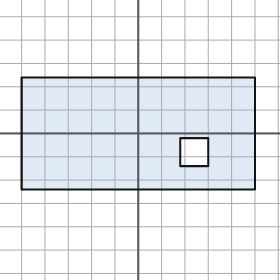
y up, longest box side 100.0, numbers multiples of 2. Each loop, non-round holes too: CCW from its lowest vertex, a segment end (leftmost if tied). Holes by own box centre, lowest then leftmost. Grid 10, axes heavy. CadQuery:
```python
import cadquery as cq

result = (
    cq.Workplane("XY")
    .moveTo(-50.0, -24.0)
    .lineTo(50.0, -24.0)
    .lineTo(50.0, 24.0)
    .lineTo(-50.0, 24.0)
    .close()
    .moveTo(18.0, -14.0)
    .lineTo(30.0, -14.0)
    .lineTo(30.0, -2.0)
    .lineTo(18.0, -2.0)
    .close()
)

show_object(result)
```